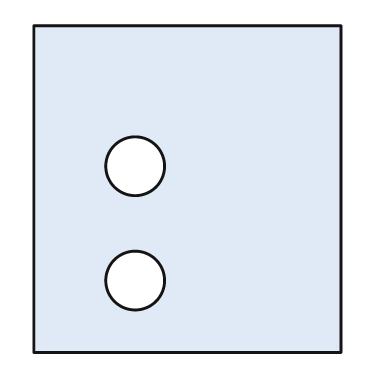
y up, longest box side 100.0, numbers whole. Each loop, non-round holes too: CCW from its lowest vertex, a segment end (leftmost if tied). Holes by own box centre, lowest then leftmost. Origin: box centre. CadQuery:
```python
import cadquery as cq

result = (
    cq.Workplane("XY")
    .moveTo(-47.0, -50.0)
    .lineTo(47.0, -50.0)
    .lineTo(47.0, 50.0)
    .lineTo(-47.0, 50.0)
    .close()
    .moveTo(-16.0, -28.0)
    .circle(9.0)
    .moveTo(-16.0, 7.0)
    .circle(9.0)
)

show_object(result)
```